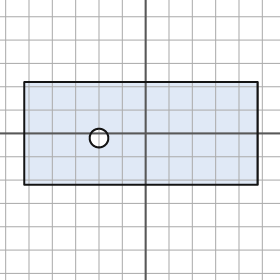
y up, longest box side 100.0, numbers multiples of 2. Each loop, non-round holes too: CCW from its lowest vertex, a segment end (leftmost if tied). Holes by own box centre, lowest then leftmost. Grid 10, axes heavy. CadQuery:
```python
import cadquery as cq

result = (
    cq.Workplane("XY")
    .moveTo(-52.0, -22.0)
    .lineTo(48.0, -22.0)
    .lineTo(48.0, 22.0)
    .lineTo(-52.0, 22.0)
    .close()
    .moveTo(-20.0, -2.0)
    .circle(4.0)
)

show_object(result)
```